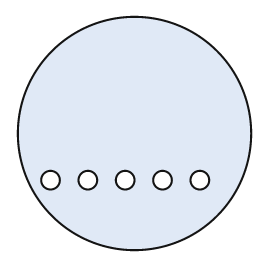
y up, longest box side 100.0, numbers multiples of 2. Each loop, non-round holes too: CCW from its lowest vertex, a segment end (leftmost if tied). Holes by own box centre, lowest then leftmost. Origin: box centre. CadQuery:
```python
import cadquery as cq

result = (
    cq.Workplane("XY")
    .moveTo(0.0, 0.0)
    .circle(50.0)
    .moveTo(-36.0, -20.0)
    .circle(4.0)
    .moveTo(-20.0, -20.0)
    .circle(4.0)
    .moveTo(-4.0, -20.0)
    .circle(4.0)
    .moveTo(12.0, -20.0)
    .circle(4.0)
    .moveTo(28.0, -20.0)
    .circle(4.0)
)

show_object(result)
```